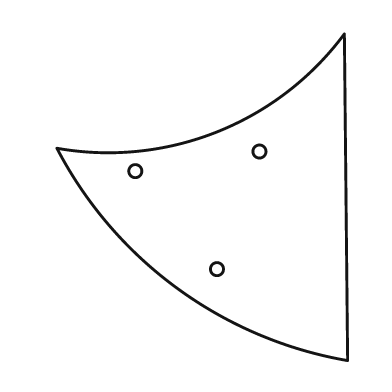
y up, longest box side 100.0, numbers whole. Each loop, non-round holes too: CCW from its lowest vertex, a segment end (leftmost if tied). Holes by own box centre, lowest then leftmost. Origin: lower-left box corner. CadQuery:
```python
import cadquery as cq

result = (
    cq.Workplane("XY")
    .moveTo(89.0, 0.0)
    .lineTo(88.0, 100.0)
    .threePointArc((49.0, 70.0), (0.0, 65.0))
    .threePointArc((37.0, 22.0), (89.0, 0.0))
    .close()
    .moveTo(49.0, 28.0)
    .circle(2.0)
    .moveTo(24.0, 58.0)
    .circle(2.0)
    .moveTo(62.0, 64.0)
    .circle(2.0)
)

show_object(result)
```